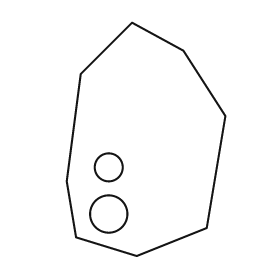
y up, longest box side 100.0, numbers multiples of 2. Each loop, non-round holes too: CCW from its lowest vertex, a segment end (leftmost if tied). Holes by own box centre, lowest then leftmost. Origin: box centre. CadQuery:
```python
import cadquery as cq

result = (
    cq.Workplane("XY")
    .moveTo(-4.0, -50.0)
    .lineTo(26.0, -38.0)
    .lineTo(34.0, 10.0)
    .lineTo(16.0, 38.0)
    .lineTo(-6.0, 50.0)
    .lineTo(-28.0, 28.0)
    .lineTo(-34.0, -18.0)
    .lineTo(-30.0, -42.0)
    .close()
    .moveTo(-16.0, -32.0)
    .circle(8.0)
    .moveTo(-16.0, -12.0)
    .circle(6.0)
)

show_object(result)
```